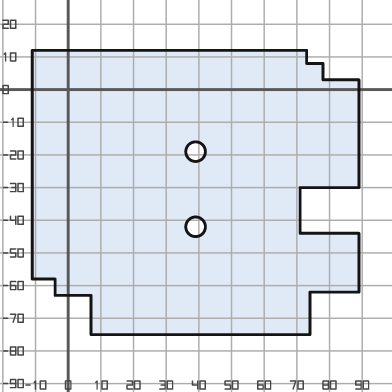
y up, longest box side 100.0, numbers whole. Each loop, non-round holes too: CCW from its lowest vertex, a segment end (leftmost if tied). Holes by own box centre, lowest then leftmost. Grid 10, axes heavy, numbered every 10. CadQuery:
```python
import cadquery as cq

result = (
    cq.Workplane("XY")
    .moveTo(7.0, -75.0)
    .lineTo(74.0, -75.0)
    .lineTo(74.0, -62.0)
    .lineTo(89.0, -62.0)
    .lineTo(89.0, -44.0)
    .lineTo(71.0, -44.0)
    .lineTo(71.0, -30.0)
    .lineTo(89.0, -30.0)
    .lineTo(89.0, 3.0)
    .lineTo(78.0, 3.0)
    .lineTo(78.0, 8.0)
    .lineTo(73.0, 8.0)
    .lineTo(73.0, 12.0)
    .lineTo(-11.0, 12.0)
    .lineTo(-11.0, -58.0)
    .lineTo(-4.0, -58.0)
    .lineTo(-4.0, -63.0)
    .lineTo(7.0, -63.0)
    .close()
    .moveTo(39.0, -42.0)
    .circle(3.0)
    .moveTo(39.0, -19.0)
    .circle(3.0)
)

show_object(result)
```